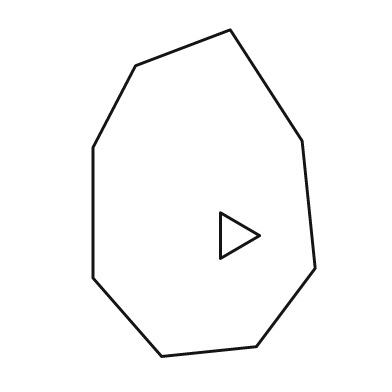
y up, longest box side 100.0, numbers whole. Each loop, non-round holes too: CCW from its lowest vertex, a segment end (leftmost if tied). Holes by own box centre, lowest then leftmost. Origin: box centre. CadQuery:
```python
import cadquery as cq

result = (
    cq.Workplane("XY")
    .moveTo(-13.0, -50.0)
    .lineTo(16.0, -47.0)
    .lineTo(34.0, -23.0)
    .lineTo(30.0, 16.0)
    .lineTo(8.0, 50.0)
    .lineTo(-21.0, 39.0)
    .lineTo(-34.0, 14.0)
    .lineTo(-34.0, -26.0)
    .close()
    .moveTo(5.0, -20.0)
    .lineTo(17.0, -13.0)
    .lineTo(5.0, -6.0)
    .close()
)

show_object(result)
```